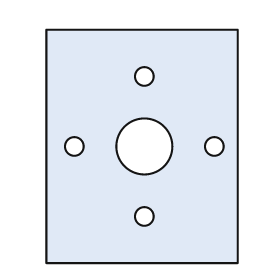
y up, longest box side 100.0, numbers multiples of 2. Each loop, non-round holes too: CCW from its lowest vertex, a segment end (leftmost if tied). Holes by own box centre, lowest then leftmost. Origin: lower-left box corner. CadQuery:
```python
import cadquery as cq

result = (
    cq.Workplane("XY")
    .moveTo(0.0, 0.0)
    .lineTo(82.0, 0.0)
    .lineTo(82.0, 100.0)
    .lineTo(0.0, 100.0)
    .close()
    .moveTo(42.0, 20.0)
    .circle(4.0)
    .moveTo(12.0, 50.0)
    .circle(4.0)
    .moveTo(42.0, 50.0)
    .circle(12.0)
    .moveTo(72.0, 50.0)
    .circle(4.0)
    .moveTo(42.0, 80.0)
    .circle(4.0)
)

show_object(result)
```